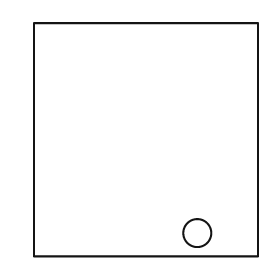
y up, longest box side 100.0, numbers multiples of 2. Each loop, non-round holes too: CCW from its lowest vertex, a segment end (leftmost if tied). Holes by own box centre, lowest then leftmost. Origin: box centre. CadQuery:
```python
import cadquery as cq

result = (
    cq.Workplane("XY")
    .moveTo(-48.0, -50.0)
    .lineTo(48.0, -50.0)
    .lineTo(48.0, 50.0)
    .lineTo(-48.0, 50.0)
    .close()
    .moveTo(22.0, -40.0)
    .circle(6.0)
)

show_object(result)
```